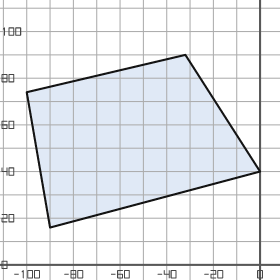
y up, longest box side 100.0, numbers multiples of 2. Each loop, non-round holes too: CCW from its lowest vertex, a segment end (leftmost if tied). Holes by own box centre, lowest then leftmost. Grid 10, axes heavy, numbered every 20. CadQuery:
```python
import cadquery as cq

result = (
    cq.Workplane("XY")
    .moveTo(-90.0, 16.0)
    .lineTo(0.0, 40.0)
    .lineTo(-32.0, 90.0)
    .lineTo(-100.0, 74.0)
    .close()
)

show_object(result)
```